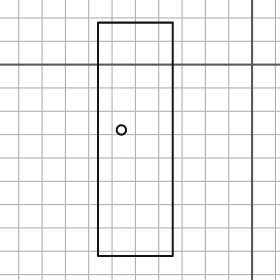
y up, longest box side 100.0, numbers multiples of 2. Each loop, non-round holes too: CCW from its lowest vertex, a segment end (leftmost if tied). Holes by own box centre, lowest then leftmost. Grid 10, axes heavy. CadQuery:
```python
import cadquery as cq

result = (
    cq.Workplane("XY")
    .moveTo(-66.0, -82.0)
    .lineTo(-34.0, -82.0)
    .lineTo(-34.0, 18.0)
    .lineTo(-66.0, 18.0)
    .close()
    .moveTo(-56.0, -28.0)
    .circle(2.0)
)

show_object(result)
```